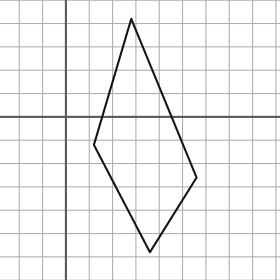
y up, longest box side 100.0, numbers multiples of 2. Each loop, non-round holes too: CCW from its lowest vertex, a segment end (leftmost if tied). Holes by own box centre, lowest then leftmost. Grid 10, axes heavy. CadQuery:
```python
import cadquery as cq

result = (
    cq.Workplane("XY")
    .moveTo(36.0, -58.0)
    .lineTo(56.0, -26.0)
    .lineTo(28.0, 42.0)
    .lineTo(12.0, -12.0)
    .close()
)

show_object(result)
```